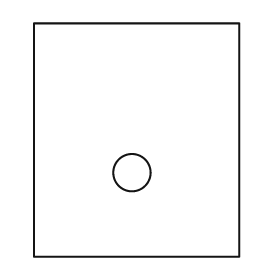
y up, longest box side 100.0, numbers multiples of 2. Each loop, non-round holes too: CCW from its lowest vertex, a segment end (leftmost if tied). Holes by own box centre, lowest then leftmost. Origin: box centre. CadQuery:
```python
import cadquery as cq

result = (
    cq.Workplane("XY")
    .moveTo(-44.0, -50.0)
    .lineTo(44.0, -50.0)
    .lineTo(44.0, 50.0)
    .lineTo(-44.0, 50.0)
    .close()
    .moveTo(-2.0, -14.0)
    .circle(8.0)
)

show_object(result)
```